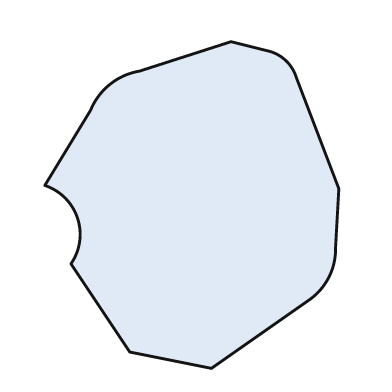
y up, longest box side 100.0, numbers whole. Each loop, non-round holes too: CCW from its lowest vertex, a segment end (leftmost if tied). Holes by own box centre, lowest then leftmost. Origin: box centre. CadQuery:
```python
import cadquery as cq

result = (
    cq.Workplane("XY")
    .moveTo(6.0, -50.0)
    .lineTo(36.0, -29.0)
    .threePointArc((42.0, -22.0), (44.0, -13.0))
    .lineTo(45.0, 5.0)
    .lineTo(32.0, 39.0)
    .threePointArc((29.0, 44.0), (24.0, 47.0))
    .lineTo(12.0, 50.0)
    .lineTo(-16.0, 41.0)
    .threePointArc((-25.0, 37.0), (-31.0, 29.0))
    .lineTo(-45.0, 6.0)
    .threePointArc((-35.0, -4.0), (-37.0, -18.0))
    .lineTo(-19.0, -45.0)
    .close()
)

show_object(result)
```